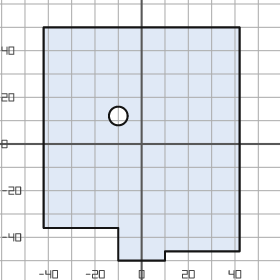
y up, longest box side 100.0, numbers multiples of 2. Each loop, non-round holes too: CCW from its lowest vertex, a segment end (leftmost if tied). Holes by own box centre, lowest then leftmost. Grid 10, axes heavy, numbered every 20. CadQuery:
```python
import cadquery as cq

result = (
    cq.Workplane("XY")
    .moveTo(-10.0, -50.0)
    .lineTo(10.0, -50.0)
    .lineTo(10.0, -46.0)
    .lineTo(42.0, -46.0)
    .lineTo(42.0, 50.0)
    .lineTo(-42.0, 50.0)
    .lineTo(-42.0, -36.0)
    .lineTo(-10.0, -36.0)
    .close()
    .moveTo(-10.0, 12.0)
    .circle(4.0)
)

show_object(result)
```